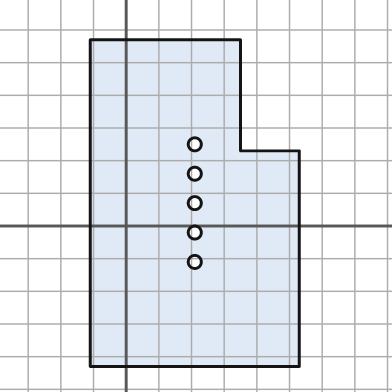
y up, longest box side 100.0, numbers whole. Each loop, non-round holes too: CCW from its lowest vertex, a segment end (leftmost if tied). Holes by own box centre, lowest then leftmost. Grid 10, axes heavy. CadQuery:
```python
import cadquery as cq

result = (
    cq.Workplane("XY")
    .moveTo(-11.0, -43.0)
    .lineTo(53.0, -43.0)
    .lineTo(53.0, 23.0)
    .lineTo(35.0, 23.0)
    .lineTo(35.0, 57.0)
    .lineTo(-11.0, 57.0)
    .close()
    .moveTo(21.0, -11.0)
    .circle(2.0)
    .moveTo(21.0, -2.0)
    .circle(2.0)
    .moveTo(21.0, 7.0)
    .circle(2.0)
    .moveTo(21.0, 16.0)
    .circle(2.0)
    .moveTo(21.0, 25.0)
    .circle(2.0)
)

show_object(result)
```